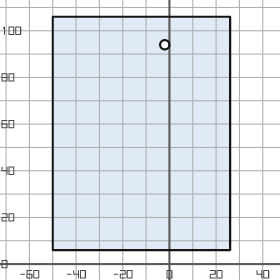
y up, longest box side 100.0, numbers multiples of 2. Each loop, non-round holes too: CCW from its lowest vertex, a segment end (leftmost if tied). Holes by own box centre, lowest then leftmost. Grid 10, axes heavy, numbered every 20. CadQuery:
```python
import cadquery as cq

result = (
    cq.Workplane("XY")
    .moveTo(-50.0, 6.0)
    .lineTo(26.0, 6.0)
    .lineTo(26.0, 106.0)
    .lineTo(-50.0, 106.0)
    .close()
    .moveTo(-2.0, 94.0)
    .circle(2.0)
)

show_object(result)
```